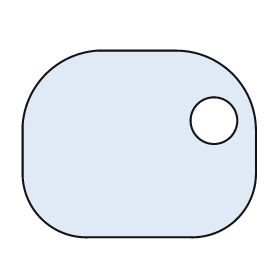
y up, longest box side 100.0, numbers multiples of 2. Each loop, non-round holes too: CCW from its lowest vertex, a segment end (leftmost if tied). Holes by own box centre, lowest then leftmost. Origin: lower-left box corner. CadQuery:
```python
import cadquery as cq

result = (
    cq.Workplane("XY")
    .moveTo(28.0, 0.0)
    .lineTo(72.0, 0.0)
    .threePointArc((92.0, 8.0), (100.0, 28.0))
    .lineTo(100.0, 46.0)
    .threePointArc((90.0, 70.0), (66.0, 80.0))
    .lineTo(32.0, 80.0)
    .threePointArc((10.0, 70.0), (0.0, 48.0))
    .lineTo(0.0, 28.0)
    .threePointArc((8.0, 8.0), (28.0, 0.0))
    .close()
    .moveTo(82.0, 50.0)
    .circle(10.0)
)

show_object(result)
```